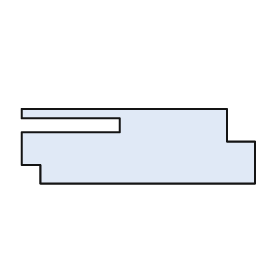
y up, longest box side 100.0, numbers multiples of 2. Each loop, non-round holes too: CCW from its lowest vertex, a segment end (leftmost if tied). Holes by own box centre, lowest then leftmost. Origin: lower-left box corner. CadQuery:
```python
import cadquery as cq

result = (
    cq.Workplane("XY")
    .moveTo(8.0, 0.0)
    .lineTo(100.0, 0.0)
    .lineTo(100.0, 18.0)
    .lineTo(88.0, 18.0)
    .lineTo(88.0, 32.0)
    .lineTo(0.0, 32.0)
    .lineTo(0.0, 28.0)
    .lineTo(42.0, 28.0)
    .lineTo(42.0, 22.0)
    .lineTo(0.0, 22.0)
    .lineTo(0.0, 8.0)
    .lineTo(8.0, 8.0)
    .close()
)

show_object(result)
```